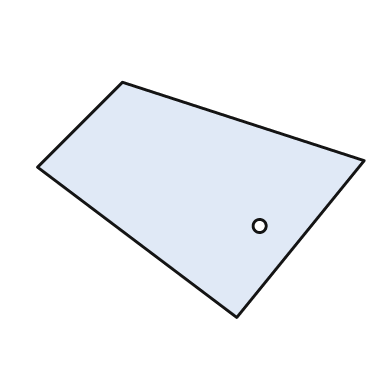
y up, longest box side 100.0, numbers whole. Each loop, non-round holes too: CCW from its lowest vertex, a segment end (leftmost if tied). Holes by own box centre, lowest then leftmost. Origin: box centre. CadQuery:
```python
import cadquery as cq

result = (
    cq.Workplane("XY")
    .moveTo(11.0, -36.0)
    .lineTo(50.0, 12.0)
    .lineTo(-24.0, 36.0)
    .lineTo(-50.0, 10.0)
    .close()
    .moveTo(18.0, -8.0)
    .circle(2.0)
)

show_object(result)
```